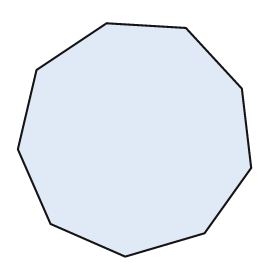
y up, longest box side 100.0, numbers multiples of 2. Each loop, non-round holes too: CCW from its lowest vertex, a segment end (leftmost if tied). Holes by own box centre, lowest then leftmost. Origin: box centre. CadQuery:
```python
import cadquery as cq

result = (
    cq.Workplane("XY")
    .moveTo(-4.0, -50.0)
    .lineTo(30.0, -40.0)
    .lineTo(50.0, -12.0)
    .lineTo(46.0, 22.0)
    .lineTo(22.0, 48.0)
    .lineTo(-12.0, 50.0)
    .lineTo(-42.0, 30.0)
    .lineTo(-50.0, -4.0)
    .lineTo(-36.0, -36.0)
    .close()
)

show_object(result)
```